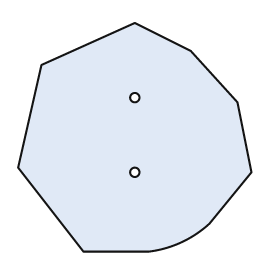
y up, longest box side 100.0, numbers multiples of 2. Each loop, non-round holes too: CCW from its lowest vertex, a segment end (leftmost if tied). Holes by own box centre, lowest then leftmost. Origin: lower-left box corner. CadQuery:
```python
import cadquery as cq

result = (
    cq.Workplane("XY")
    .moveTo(28.0, 0.0)
    .lineTo(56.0, 0.0)
    .threePointArc((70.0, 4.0), (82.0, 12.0))
    .lineTo(100.0, 34.0)
    .lineTo(94.0, 64.0)
    .lineTo(74.0, 86.0)
    .lineTo(50.0, 98.0)
    .lineTo(10.0, 80.0)
    .lineTo(0.0, 36.0)
    .close()
    .moveTo(50.0, 34.0)
    .circle(2.0)
    .moveTo(50.0, 66.0)
    .circle(2.0)
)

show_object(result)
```